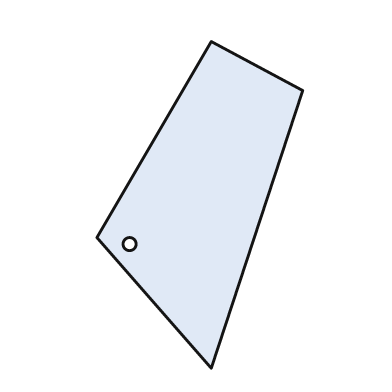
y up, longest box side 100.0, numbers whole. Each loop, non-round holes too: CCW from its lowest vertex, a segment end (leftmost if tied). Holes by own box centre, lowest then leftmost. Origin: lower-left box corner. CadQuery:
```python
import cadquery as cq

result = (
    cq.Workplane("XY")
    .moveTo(35.0, 0.0)
    .lineTo(63.0, 85.0)
    .lineTo(35.0, 100.0)
    .lineTo(0.0, 40.0)
    .close()
    .moveTo(10.0, 38.0)
    .circle(2.0)
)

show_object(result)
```